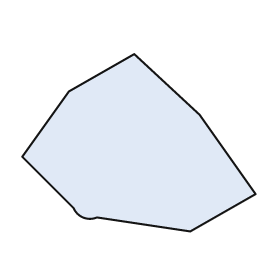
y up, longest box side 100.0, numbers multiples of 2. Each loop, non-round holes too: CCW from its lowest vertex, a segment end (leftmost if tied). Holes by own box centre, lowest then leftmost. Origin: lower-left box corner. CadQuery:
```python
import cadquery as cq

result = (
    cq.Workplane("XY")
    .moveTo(72.0, 0.0)
    .lineTo(100.0, 16.0)
    .lineTo(76.0, 50.0)
    .lineTo(48.0, 76.0)
    .lineTo(20.0, 60.0)
    .lineTo(0.0, 32.0)
    .lineTo(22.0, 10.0)
    .threePointArc((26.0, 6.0), (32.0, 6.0))
    .close()
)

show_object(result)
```